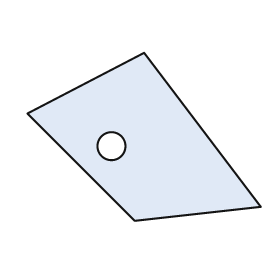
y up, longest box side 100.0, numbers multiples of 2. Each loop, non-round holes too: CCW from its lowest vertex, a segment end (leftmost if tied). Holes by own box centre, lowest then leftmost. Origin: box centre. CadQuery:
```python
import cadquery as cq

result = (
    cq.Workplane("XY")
    .moveTo(-4.0, -36.0)
    .lineTo(50.0, -30.0)
    .lineTo(0.0, 36.0)
    .lineTo(-50.0, 10.0)
    .close()
    .moveTo(-14.0, -4.0)
    .circle(6.0)
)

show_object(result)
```